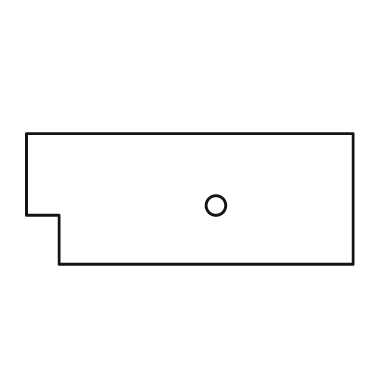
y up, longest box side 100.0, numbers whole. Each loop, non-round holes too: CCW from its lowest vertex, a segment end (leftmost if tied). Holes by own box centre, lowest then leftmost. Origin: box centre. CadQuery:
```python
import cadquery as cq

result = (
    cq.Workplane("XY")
    .moveTo(-40.0, -20.0)
    .lineTo(50.0, -20.0)
    .lineTo(50.0, 20.0)
    .lineTo(-50.0, 20.0)
    .lineTo(-50.0, -5.0)
    .lineTo(-40.0, -5.0)
    .close()
    .moveTo(8.0, -2.0)
    .circle(3.0)
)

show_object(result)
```